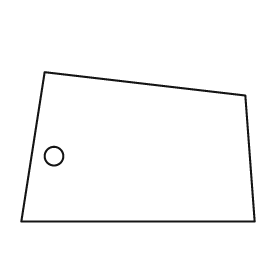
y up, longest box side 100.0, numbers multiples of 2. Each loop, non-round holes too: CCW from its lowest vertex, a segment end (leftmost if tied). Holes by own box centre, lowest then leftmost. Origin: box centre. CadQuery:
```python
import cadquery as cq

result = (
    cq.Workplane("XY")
    .moveTo(-50.0, -32.0)
    .lineTo(50.0, -32.0)
    .lineTo(46.0, 22.0)
    .lineTo(-40.0, 32.0)
    .close()
    .moveTo(-36.0, -4.0)
    .circle(4.0)
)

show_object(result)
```